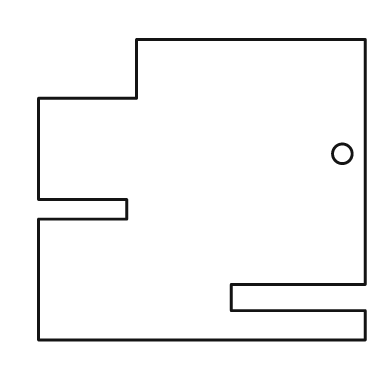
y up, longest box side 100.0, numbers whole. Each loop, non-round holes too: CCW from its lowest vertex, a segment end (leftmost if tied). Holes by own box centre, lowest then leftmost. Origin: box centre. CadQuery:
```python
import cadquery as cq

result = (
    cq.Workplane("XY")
    .moveTo(-50.0, -46.0)
    .lineTo(50.0, -46.0)
    .lineTo(50.0, -37.0)
    .lineTo(9.0, -37.0)
    .lineTo(9.0, -29.0)
    .lineTo(50.0, -29.0)
    .lineTo(50.0, 46.0)
    .lineTo(-20.0, 46.0)
    .lineTo(-20.0, 28.0)
    .lineTo(-50.0, 28.0)
    .lineTo(-50.0, -3.0)
    .lineTo(-23.0, -3.0)
    .lineTo(-23.0, -9.0)
    .lineTo(-50.0, -9.0)
    .close()
    .moveTo(43.0, 11.0)
    .circle(3.0)
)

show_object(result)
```